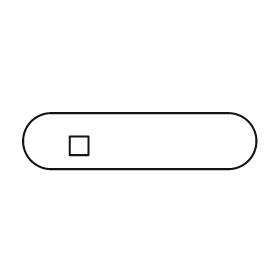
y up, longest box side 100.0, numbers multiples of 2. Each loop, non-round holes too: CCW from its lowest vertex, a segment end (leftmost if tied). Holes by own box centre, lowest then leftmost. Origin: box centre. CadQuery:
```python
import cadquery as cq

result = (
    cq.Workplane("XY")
    .moveTo(-38.0, -12.0)
    .lineTo(38.0, -12.0)
    .threePointArc((50.0, 0.0), (38.0, 12.0))
    .lineTo(-38.0, 12.0)
    .threePointArc((-50.0, 0.0), (-38.0, -12.0))
    .close()
    .moveTo(-30.0, -6.0)
    .lineTo(-22.0, -6.0)
    .lineTo(-22.0, 2.0)
    .lineTo(-30.0, 2.0)
    .close()
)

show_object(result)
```